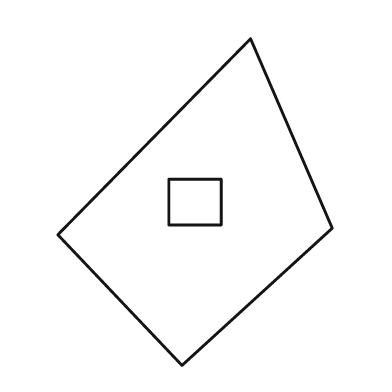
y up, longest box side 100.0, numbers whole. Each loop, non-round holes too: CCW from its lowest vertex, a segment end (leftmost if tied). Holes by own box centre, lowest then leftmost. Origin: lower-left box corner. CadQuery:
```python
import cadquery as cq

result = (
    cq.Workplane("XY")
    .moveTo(38.0, 0.0)
    .lineTo(84.0, 42.0)
    .lineTo(59.0, 100.0)
    .lineTo(0.0, 40.0)
    .close()
    .moveTo(34.0, 43.0)
    .lineTo(50.0, 43.0)
    .lineTo(50.0, 57.0)
    .lineTo(34.0, 57.0)
    .close()
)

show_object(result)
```